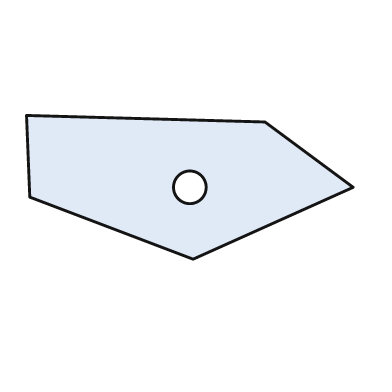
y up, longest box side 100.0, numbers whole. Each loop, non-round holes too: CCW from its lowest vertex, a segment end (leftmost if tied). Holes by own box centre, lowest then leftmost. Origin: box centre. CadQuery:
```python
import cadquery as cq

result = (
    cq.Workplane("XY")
    .moveTo(1.0, -22.0)
    .lineTo(50.0, 0.0)
    .lineTo(23.0, 20.0)
    .lineTo(-50.0, 22.0)
    .lineTo(-49.0, -3.0)
    .close()
    .moveTo(0.0, 0.0)
    .circle(5.0)
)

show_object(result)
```